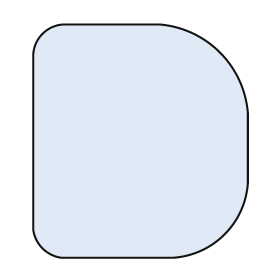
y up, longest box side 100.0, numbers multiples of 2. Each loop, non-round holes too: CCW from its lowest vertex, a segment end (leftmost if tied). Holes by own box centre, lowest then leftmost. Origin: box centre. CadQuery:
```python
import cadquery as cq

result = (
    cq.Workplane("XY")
    .moveTo(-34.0, -50.0)
    .lineTo(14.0, -50.0)
    .threePointArc((36.0, -40.0), (46.0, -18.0))
    .lineTo(46.0, 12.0)
    .threePointArc((34.0, 38.0), (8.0, 50.0))
    .lineTo(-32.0, 50.0)
    .threePointArc((-42.0, 46.0), (-46.0, 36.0))
    .lineTo(-46.0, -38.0)
    .threePointArc((-42.0, -46.0), (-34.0, -50.0))
    .close()
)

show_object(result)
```